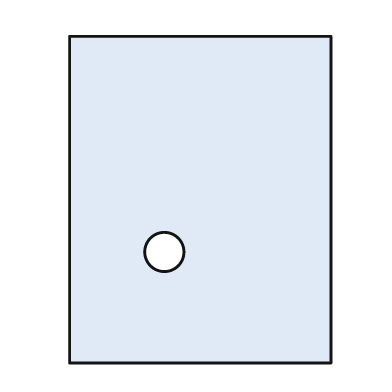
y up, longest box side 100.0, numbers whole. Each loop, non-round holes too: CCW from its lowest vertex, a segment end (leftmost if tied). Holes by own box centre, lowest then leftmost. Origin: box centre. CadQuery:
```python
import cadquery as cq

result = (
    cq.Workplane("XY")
    .moveTo(-40.0, -50.0)
    .lineTo(40.0, -50.0)
    .lineTo(40.0, 50.0)
    .lineTo(-40.0, 50.0)
    .close()
    .moveTo(-11.0, -16.0)
    .circle(6.0)
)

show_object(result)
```